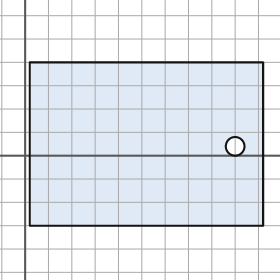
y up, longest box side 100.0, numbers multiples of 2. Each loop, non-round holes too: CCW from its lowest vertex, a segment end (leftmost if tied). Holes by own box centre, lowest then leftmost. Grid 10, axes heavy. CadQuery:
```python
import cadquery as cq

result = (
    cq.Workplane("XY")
    .moveTo(2.0, -30.0)
    .lineTo(102.0, -30.0)
    .lineTo(102.0, 40.0)
    .lineTo(2.0, 40.0)
    .close()
    .moveTo(90.0, 4.0)
    .circle(4.0)
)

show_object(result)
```